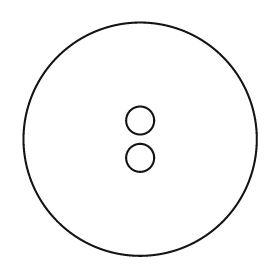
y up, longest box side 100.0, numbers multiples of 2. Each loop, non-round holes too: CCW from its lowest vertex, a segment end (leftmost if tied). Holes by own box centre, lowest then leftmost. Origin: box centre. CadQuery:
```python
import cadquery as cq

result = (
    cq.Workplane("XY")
    .moveTo(0.0, 0.0)
    .circle(50.0)
    .moveTo(0.0, -8.0)
    .circle(6.0)
    .moveTo(0.0, 8.0)
    .circle(6.0)
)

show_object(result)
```